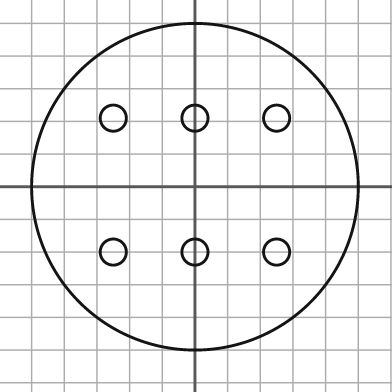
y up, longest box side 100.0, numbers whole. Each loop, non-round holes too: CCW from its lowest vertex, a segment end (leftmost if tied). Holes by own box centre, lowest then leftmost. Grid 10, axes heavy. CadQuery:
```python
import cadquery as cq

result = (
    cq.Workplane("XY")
    .moveTo(0.0, 0.0)
    .circle(50.0)
    .moveTo(-25.0, -20.0)
    .circle(4.0)
    .moveTo(0.0, -20.0)
    .circle(4.0)
    .moveTo(25.0, -20.0)
    .circle(4.0)
    .moveTo(-25.0, 21.0)
    .circle(4.0)
    .moveTo(0.0, 21.0)
    .circle(4.0)
    .moveTo(25.0, 21.0)
    .circle(4.0)
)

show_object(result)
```